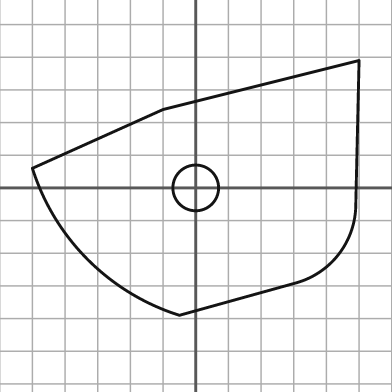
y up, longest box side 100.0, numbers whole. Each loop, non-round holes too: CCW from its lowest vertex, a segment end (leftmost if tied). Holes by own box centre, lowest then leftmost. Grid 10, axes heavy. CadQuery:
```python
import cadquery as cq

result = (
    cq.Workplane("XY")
    .moveTo(-5.0, -39.0)
    .lineTo(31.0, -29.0)
    .threePointArc((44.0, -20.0), (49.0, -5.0))
    .lineTo(50.0, 39.0)
    .lineTo(-10.0, 24.0)
    .lineTo(-50.0, 6.0)
    .threePointArc((-33.0, -22.0), (-5.0, -39.0))
    .close()
    .moveTo(0.0, 0.0)
    .circle(7.0)
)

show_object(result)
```